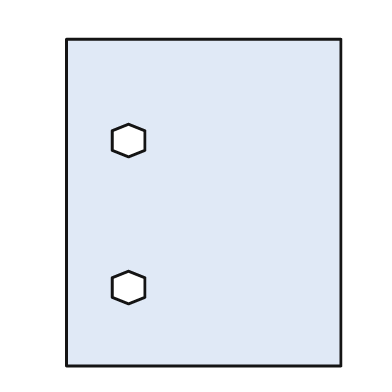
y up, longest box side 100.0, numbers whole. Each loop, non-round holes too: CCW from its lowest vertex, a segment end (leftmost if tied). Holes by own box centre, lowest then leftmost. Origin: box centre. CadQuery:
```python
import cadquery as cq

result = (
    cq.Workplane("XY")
    .moveTo(-42.0, -50.0)
    .lineTo(42.0, -50.0)
    .lineTo(42.0, 50.0)
    .lineTo(-42.0, 50.0)
    .close()
    .moveTo(-23.0, -31.0)
    .lineTo(-18.0, -29.0)
    .lineTo(-18.0, -23.0)
    .lineTo(-23.0, -21.0)
    .lineTo(-28.0, -23.0)
    .lineTo(-28.0, -29.0)
    .close()
    .moveTo(-23.0, 14.0)
    .lineTo(-18.0, 16.0)
    .lineTo(-18.0, 22.0)
    .lineTo(-23.0, 24.0)
    .lineTo(-28.0, 22.0)
    .lineTo(-28.0, 16.0)
    .close()
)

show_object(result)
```